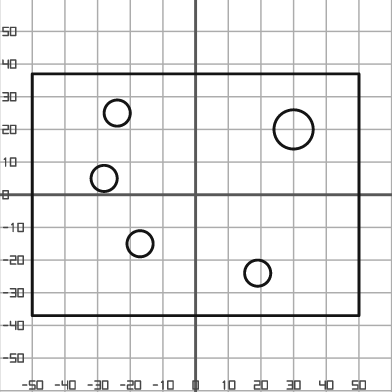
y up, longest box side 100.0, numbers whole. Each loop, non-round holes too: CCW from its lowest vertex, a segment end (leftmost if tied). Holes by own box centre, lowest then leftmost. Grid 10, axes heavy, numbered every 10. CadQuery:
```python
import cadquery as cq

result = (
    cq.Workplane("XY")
    .moveTo(-50.0, -37.0)
    .lineTo(50.0, -37.0)
    .lineTo(50.0, 37.0)
    .lineTo(-50.0, 37.0)
    .close()
    .moveTo(19.0, -24.0)
    .circle(4.0)
    .moveTo(-17.0, -15.0)
    .circle(4.0)
    .moveTo(-28.0, 5.0)
    .circle(4.0)
    .moveTo(30.0, 20.0)
    .circle(6.0)
    .moveTo(-24.0, 25.0)
    .circle(4.0)
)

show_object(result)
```